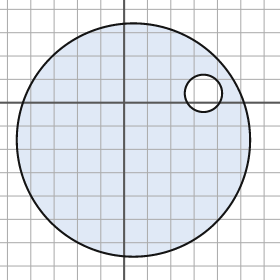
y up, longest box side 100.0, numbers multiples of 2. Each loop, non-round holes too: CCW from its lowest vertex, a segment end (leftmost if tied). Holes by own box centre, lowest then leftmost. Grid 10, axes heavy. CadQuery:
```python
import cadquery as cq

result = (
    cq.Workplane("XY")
    .moveTo(4.0, -16.0)
    .circle(50.0)
    .moveTo(34.0, 4.0)
    .circle(8.0)
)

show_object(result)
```